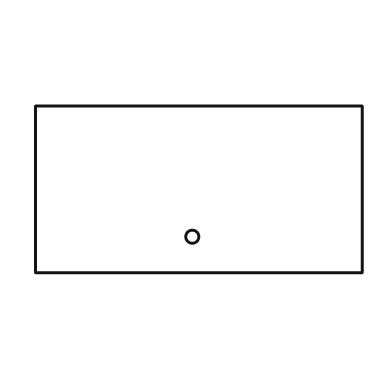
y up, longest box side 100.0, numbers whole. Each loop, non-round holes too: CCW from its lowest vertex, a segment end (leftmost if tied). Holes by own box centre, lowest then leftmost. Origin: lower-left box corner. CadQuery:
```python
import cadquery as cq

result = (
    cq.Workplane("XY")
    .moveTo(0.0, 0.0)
    .lineTo(100.0, 0.0)
    .lineTo(100.0, 51.0)
    .lineTo(0.0, 51.0)
    .close()
    .moveTo(48.0, 11.0)
    .circle(2.0)
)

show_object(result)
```